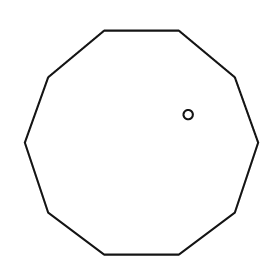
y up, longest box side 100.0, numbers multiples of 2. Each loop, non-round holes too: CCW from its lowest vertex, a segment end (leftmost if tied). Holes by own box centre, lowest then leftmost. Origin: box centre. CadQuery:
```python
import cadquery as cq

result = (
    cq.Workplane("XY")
    .moveTo(-16.0, -48.0)
    .lineTo(16.0, -48.0)
    .lineTo(40.0, -30.0)
    .lineTo(50.0, 0.0)
    .lineTo(40.0, 28.0)
    .lineTo(16.0, 48.0)
    .lineTo(-16.0, 48.0)
    .lineTo(-40.0, 28.0)
    .lineTo(-50.0, 0.0)
    .lineTo(-40.0, -30.0)
    .close()
    .moveTo(20.0, 12.0)
    .circle(2.0)
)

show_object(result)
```